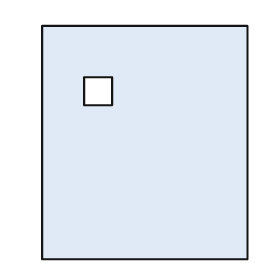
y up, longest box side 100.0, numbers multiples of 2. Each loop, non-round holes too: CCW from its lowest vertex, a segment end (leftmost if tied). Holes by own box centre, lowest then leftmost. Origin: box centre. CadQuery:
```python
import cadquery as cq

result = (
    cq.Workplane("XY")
    .moveTo(-44.0, -50.0)
    .lineTo(44.0, -50.0)
    .lineTo(44.0, 50.0)
    .lineTo(-44.0, 50.0)
    .close()
    .moveTo(-26.0, 16.0)
    .lineTo(-14.0, 16.0)
    .lineTo(-14.0, 28.0)
    .lineTo(-26.0, 28.0)
    .close()
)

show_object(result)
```